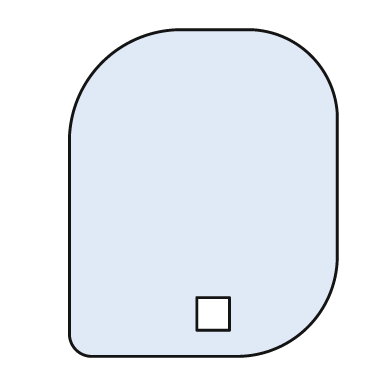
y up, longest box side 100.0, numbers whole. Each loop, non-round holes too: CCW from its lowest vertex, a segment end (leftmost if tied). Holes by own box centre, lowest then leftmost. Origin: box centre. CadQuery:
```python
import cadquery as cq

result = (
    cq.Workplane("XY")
    .moveTo(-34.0, -50.0)
    .lineTo(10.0, -50.0)
    .threePointArc((32.0, -41.0), (41.0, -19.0))
    .lineTo(41.0, 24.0)
    .threePointArc((33.0, 42.0), (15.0, 50.0))
    .lineTo(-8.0, 50.0)
    .threePointArc((-31.0, 40.0), (-41.0, 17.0))
    .lineTo(-41.0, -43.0)
    .threePointArc((-39.0, -48.0), (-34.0, -50.0))
    .close()
    .moveTo(-2.0, -42.0)
    .lineTo(8.0, -42.0)
    .lineTo(8.0, -32.0)
    .lineTo(-2.0, -32.0)
    .close()
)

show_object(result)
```